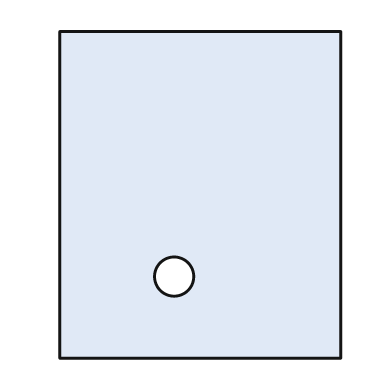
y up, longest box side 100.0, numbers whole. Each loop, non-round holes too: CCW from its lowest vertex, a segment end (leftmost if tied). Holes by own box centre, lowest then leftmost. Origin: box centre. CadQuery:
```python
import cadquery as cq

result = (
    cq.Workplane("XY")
    .moveTo(-43.0, -50.0)
    .lineTo(43.0, -50.0)
    .lineTo(43.0, 50.0)
    .lineTo(-43.0, 50.0)
    .close()
    .moveTo(-8.0, -25.0)
    .circle(6.0)
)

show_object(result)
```